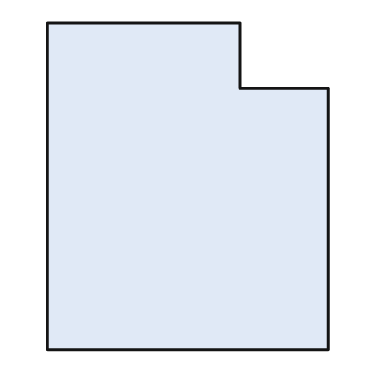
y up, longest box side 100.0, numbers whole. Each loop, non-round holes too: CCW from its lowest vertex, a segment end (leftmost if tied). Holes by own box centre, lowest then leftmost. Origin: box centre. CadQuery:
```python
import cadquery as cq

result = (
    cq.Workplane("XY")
    .moveTo(-43.0, -50.0)
    .lineTo(43.0, -50.0)
    .lineTo(43.0, 30.0)
    .lineTo(16.0, 30.0)
    .lineTo(16.0, 50.0)
    .lineTo(-43.0, 50.0)
    .close()
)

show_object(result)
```